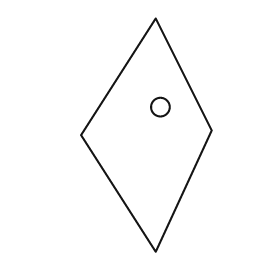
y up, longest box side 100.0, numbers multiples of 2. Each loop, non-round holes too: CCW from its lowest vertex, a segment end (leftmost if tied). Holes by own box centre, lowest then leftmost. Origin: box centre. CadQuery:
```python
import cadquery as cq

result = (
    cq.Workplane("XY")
    .moveTo(4.0, -50.0)
    .lineTo(28.0, 2.0)
    .lineTo(4.0, 50.0)
    .lineTo(-28.0, 0.0)
    .close()
    .moveTo(6.0, 12.0)
    .circle(4.0)
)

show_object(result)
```